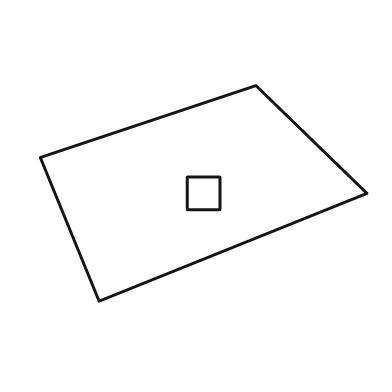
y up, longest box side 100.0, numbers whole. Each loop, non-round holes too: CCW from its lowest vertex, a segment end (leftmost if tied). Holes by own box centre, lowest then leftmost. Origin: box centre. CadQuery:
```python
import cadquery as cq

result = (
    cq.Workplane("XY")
    .moveTo(-32.0, -33.0)
    .lineTo(50.0, 0.0)
    .lineTo(16.0, 33.0)
    .lineTo(-50.0, 11.0)
    .close()
    .moveTo(-5.0, -5.0)
    .lineTo(5.0, -5.0)
    .lineTo(5.0, 5.0)
    .lineTo(-5.0, 5.0)
    .close()
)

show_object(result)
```